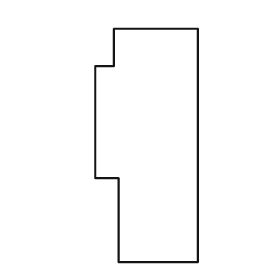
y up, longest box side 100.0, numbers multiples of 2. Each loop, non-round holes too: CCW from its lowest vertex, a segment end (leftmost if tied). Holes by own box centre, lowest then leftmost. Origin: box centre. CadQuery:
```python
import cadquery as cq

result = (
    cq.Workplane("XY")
    .moveTo(-12.0, -50.0)
    .lineTo(22.0, -50.0)
    .lineTo(22.0, 50.0)
    .lineTo(-14.0, 50.0)
    .lineTo(-14.0, 34.0)
    .lineTo(-22.0, 34.0)
    .lineTo(-22.0, -14.0)
    .lineTo(-12.0, -14.0)
    .close()
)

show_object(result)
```